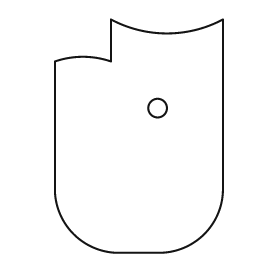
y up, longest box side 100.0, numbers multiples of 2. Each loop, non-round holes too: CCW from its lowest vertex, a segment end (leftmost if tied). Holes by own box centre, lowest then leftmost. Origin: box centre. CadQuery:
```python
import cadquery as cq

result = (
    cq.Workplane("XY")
    .moveTo(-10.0, -50.0)
    .lineTo(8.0, -50.0)
    .threePointArc((28.0, -42.0), (36.0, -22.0))
    .lineTo(36.0, 50.0)
    .threePointArc((12.0, 44.0), (-12.0, 50.0))
    .lineTo(-12.0, 32.0)
    .threePointArc((-24.0, 34.0), (-36.0, 32.0))
    .lineTo(-36.0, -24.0)
    .threePointArc((-28.0, -42.0), (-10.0, -50.0))
    .close()
    .moveTo(8.0, 12.0)
    .circle(4.0)
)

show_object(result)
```